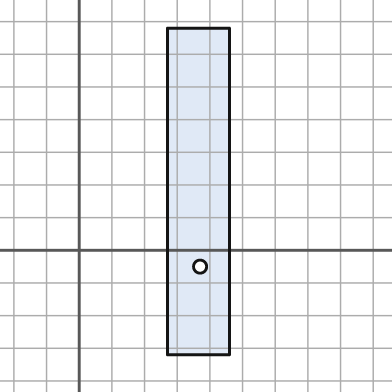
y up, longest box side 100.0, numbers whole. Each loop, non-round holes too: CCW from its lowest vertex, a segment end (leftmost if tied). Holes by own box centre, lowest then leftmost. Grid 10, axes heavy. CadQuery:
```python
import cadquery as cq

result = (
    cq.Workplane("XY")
    .moveTo(27.0, -32.0)
    .lineTo(46.0, -32.0)
    .lineTo(46.0, 68.0)
    .lineTo(27.0, 68.0)
    .close()
    .moveTo(37.0, -5.0)
    .circle(2.0)
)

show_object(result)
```